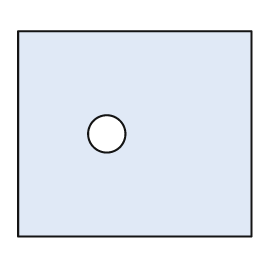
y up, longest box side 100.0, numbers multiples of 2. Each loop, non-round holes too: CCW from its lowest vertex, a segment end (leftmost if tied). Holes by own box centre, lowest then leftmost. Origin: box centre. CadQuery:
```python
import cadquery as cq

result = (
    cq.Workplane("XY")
    .moveTo(-50.0, -44.0)
    .lineTo(50.0, -44.0)
    .lineTo(50.0, 44.0)
    .lineTo(-50.0, 44.0)
    .close()
    .moveTo(-12.0, 0.0)
    .circle(8.0)
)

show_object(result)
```